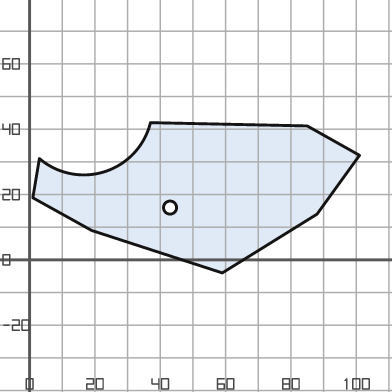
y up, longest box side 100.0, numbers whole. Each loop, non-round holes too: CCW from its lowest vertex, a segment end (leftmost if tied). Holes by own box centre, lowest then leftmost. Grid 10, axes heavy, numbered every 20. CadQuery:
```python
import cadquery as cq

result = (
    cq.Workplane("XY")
    .moveTo(59.0, -4.0)
    .lineTo(88.0, 14.0)
    .lineTo(101.0, 32.0)
    .lineTo(85.0, 41.0)
    .lineTo(37.0, 42.0)
    .threePointArc((23.0, 27.0), (3.0, 31.0))
    .lineTo(1.0, 19.0)
    .lineTo(19.0, 9.0)
    .close()
    .moveTo(43.0, 16.0)
    .circle(2.0)
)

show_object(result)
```